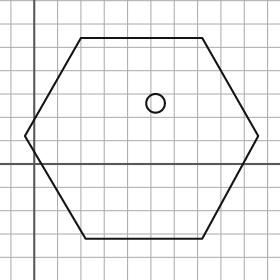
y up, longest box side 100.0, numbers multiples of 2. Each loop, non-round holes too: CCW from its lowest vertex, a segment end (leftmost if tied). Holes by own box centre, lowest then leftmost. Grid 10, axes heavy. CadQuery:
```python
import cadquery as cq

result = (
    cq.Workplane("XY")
    .moveTo(22.0, -32.0)
    .lineTo(72.0, -32.0)
    .lineTo(96.0, 12.0)
    .lineTo(72.0, 54.0)
    .lineTo(20.0, 54.0)
    .lineTo(-4.0, 12.0)
    .close()
    .moveTo(52.0, 26.0)
    .circle(4.0)
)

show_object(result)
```